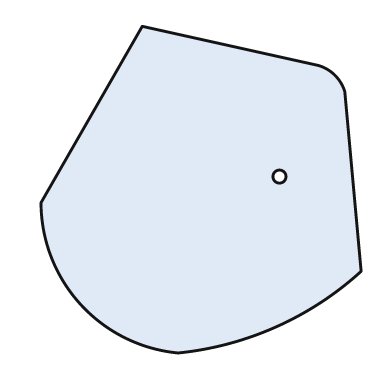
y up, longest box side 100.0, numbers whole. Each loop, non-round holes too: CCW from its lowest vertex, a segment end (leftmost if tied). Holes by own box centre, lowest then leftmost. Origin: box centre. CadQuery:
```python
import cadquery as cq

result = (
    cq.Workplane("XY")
    .moveTo(-7.0, -50.0)
    .threePointArc((23.0, -42.0), (49.0, -25.0))
    .lineTo(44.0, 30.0)
    .threePointArc((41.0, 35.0), (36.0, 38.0))
    .lineTo(-18.0, 50.0)
    .lineTo(-49.0, -4.0)
    .threePointArc((-37.0, -35.0), (-7.0, -50.0))
    .close()
    .moveTo(24.0, 4.0)
    .circle(2.0)
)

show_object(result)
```